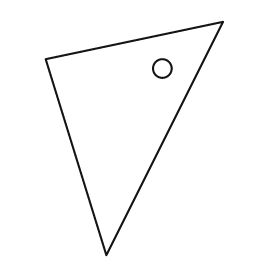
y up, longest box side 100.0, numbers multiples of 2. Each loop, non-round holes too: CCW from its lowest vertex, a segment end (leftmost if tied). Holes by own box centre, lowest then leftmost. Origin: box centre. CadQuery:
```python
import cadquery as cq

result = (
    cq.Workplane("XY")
    .moveTo(-12.0, -50.0)
    .lineTo(38.0, 50.0)
    .lineTo(-38.0, 34.0)
    .close()
    .moveTo(12.0, 30.0)
    .circle(4.0)
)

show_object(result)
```